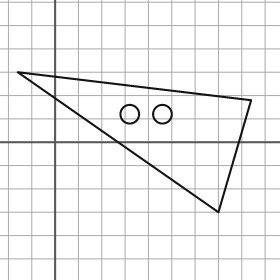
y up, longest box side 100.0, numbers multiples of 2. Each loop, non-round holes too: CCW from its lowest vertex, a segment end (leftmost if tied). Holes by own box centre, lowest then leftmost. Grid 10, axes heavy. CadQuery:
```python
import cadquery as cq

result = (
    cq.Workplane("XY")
    .moveTo(70.0, -30.0)
    .lineTo(84.0, 18.0)
    .lineTo(-16.0, 30.0)
    .close()
    .moveTo(32.0, 12.0)
    .circle(4.0)
    .moveTo(46.0, 12.0)
    .circle(4.0)
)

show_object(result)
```